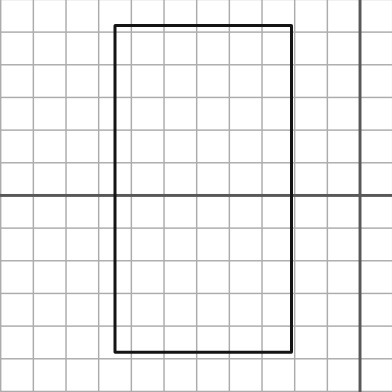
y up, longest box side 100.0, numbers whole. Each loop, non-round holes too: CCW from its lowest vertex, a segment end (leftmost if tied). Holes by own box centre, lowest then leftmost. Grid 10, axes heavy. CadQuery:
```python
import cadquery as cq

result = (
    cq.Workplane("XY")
    .moveTo(-75.0, -48.0)
    .lineTo(-21.0, -48.0)
    .lineTo(-21.0, 52.0)
    .lineTo(-75.0, 52.0)
    .close()
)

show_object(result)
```